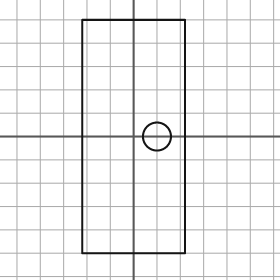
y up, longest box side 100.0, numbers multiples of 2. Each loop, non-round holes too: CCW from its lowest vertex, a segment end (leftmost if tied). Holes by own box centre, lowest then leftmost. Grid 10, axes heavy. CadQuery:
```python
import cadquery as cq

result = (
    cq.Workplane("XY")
    .moveTo(-22.0, -50.0)
    .lineTo(22.0, -50.0)
    .lineTo(22.0, 50.0)
    .lineTo(-22.0, 50.0)
    .close()
    .moveTo(10.0, 0.0)
    .circle(6.0)
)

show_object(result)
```